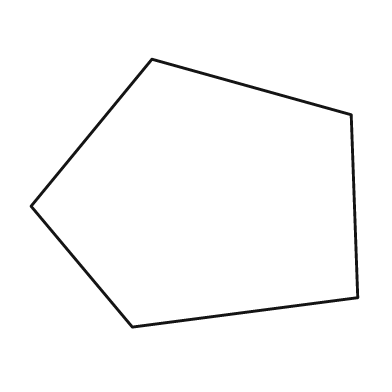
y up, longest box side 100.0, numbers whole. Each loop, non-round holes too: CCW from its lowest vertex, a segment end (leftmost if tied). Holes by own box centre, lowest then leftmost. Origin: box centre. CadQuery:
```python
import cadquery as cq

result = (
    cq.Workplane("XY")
    .moveTo(-19.0, -41.0)
    .lineTo(50.0, -32.0)
    .lineTo(48.0, 24.0)
    .lineTo(-13.0, 41.0)
    .lineTo(-50.0, -4.0)
    .close()
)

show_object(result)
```